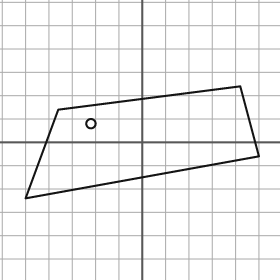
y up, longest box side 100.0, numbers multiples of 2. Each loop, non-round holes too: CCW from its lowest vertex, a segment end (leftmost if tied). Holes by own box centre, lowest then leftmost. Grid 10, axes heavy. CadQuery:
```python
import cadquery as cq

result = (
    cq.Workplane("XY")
    .moveTo(-50.0, -24.0)
    .lineTo(50.0, -6.0)
    .lineTo(42.0, 24.0)
    .lineTo(-36.0, 14.0)
    .close()
    .moveTo(-22.0, 8.0)
    .circle(2.0)
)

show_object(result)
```